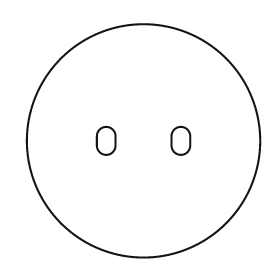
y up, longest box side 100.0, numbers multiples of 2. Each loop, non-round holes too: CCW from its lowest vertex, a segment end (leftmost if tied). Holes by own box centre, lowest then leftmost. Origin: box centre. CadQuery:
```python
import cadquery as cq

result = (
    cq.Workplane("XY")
    .moveTo(0.0, 0.0)
    .circle(50.0)
    .moveTo(-20.0, -2.0)
    .threePointArc((-16.0, -6.0), (-12.0, -2.0))
    .lineTo(-12.0, 2.0)
    .threePointArc((-16.0, 6.0), (-20.0, 2.0))
    .close()
    .moveTo(12.0, -2.0)
    .threePointArc((16.0, -6.0), (20.0, -2.0))
    .lineTo(20.0, 2.0)
    .threePointArc((16.0, 6.0), (12.0, 2.0))
    .close()
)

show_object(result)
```